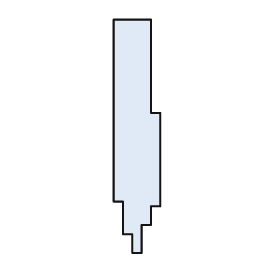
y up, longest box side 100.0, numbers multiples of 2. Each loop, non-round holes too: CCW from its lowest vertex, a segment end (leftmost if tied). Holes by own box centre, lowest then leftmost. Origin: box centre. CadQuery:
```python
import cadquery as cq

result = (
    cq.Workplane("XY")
    .moveTo(-2.0, -50.0)
    .lineTo(2.0, -50.0)
    .lineTo(2.0, -38.0)
    .lineTo(6.0, -38.0)
    .lineTo(6.0, -30.0)
    .lineTo(10.0, -30.0)
    .lineTo(10.0, 10.0)
    .lineTo(6.0, 10.0)
    .lineTo(6.0, 50.0)
    .lineTo(-10.0, 50.0)
    .lineTo(-10.0, -28.0)
    .lineTo(-6.0, -28.0)
    .lineTo(-6.0, -42.0)
    .lineTo(-2.0, -42.0)
    .close()
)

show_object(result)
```